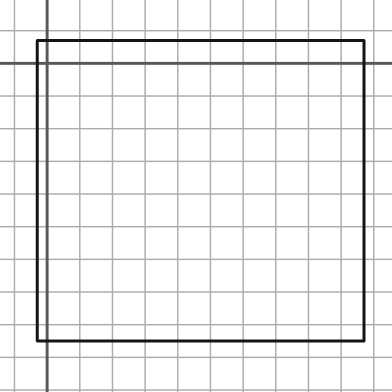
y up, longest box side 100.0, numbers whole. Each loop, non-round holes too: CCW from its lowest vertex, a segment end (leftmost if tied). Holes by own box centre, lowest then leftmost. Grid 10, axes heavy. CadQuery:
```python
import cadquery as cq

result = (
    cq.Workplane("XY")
    .moveTo(-3.0, -85.0)
    .lineTo(97.0, -85.0)
    .lineTo(97.0, 7.0)
    .lineTo(-3.0, 7.0)
    .close()
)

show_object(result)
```